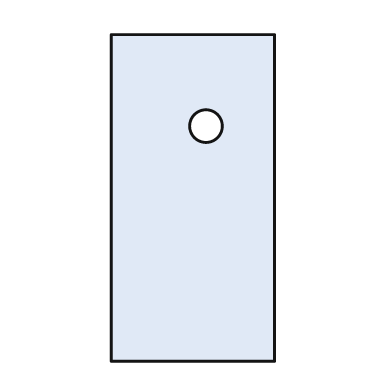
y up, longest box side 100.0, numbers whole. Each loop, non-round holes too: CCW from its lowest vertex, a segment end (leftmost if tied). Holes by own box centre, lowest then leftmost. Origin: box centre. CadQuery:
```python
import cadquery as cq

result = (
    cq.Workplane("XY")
    .moveTo(-25.0, -50.0)
    .lineTo(25.0, -50.0)
    .lineTo(25.0, 50.0)
    .lineTo(-25.0, 50.0)
    .close()
    .moveTo(4.0, 22.0)
    .circle(5.0)
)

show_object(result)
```